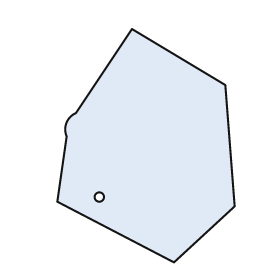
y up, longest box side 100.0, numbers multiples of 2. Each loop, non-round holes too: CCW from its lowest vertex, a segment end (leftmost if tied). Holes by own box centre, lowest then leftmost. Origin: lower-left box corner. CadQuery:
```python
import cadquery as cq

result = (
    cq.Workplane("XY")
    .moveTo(50.0, 0.0)
    .lineTo(76.0, 24.0)
    .lineTo(72.0, 76.0)
    .lineTo(32.0, 100.0)
    .lineTo(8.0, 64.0)
    .threePointArc((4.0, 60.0), (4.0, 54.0))
    .lineTo(0.0, 26.0)
    .close()
    .moveTo(18.0, 28.0)
    .circle(2.0)
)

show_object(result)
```